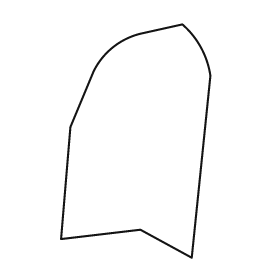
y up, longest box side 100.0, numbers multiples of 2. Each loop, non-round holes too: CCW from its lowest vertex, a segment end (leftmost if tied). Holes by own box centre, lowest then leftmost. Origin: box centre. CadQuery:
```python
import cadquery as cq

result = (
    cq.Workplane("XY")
    .moveTo(24.0, -50.0)
    .lineTo(32.0, 28.0)
    .threePointArc((28.0, 40.0), (20.0, 50.0))
    .lineTo(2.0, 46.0)
    .threePointArc((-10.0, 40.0), (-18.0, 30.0))
    .lineTo(-28.0, 6.0)
    .lineTo(-32.0, -42.0)
    .lineTo(2.0, -38.0)
    .close()
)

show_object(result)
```